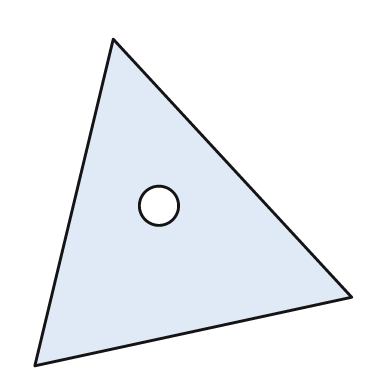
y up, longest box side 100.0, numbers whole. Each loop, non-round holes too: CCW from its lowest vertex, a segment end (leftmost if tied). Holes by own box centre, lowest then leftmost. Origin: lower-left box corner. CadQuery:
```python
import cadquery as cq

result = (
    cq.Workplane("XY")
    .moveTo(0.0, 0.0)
    .lineTo(97.0, 21.0)
    .lineTo(24.0, 100.0)
    .close()
    .moveTo(38.0, 49.0)
    .circle(6.0)
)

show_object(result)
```